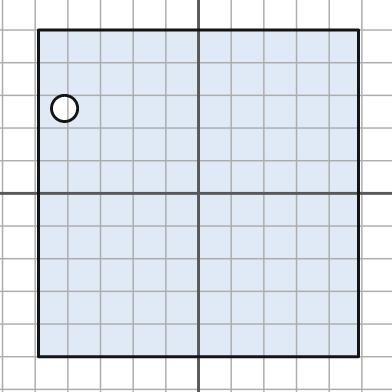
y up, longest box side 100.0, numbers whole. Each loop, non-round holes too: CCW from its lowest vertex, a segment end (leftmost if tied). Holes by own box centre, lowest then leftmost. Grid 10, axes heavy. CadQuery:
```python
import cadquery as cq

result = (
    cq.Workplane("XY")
    .moveTo(-49.0, -50.0)
    .lineTo(49.0, -50.0)
    .lineTo(49.0, 50.0)
    .lineTo(-49.0, 50.0)
    .close()
    .moveTo(-41.0, 26.0)
    .circle(4.0)
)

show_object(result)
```